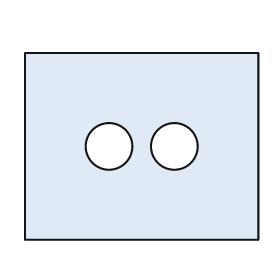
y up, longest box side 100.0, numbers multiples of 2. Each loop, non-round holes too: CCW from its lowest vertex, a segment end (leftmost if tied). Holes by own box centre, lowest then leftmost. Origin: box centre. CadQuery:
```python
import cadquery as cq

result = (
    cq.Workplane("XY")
    .moveTo(-50.0, -40.0)
    .lineTo(50.0, -40.0)
    .lineTo(50.0, 40.0)
    .lineTo(-50.0, 40.0)
    .close()
    .moveTo(-14.0, 0.0)
    .circle(10.0)
    .moveTo(14.0, 0.0)
    .circle(10.0)
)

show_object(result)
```